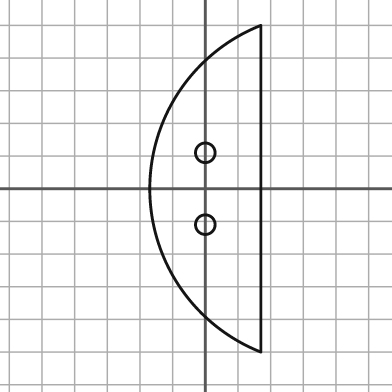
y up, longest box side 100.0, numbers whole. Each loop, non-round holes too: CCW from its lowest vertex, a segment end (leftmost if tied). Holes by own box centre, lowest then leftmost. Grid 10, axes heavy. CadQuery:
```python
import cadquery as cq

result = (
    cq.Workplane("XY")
    .moveTo(17.0, -50.0)
    .lineTo(17.0, 50.0)
    .threePointArc((-17.0, 0.0), (17.0, -50.0))
    .close()
    .moveTo(0.0, -11.0)
    .circle(3.0)
    .moveTo(0.0, 11.0)
    .circle(3.0)
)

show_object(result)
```